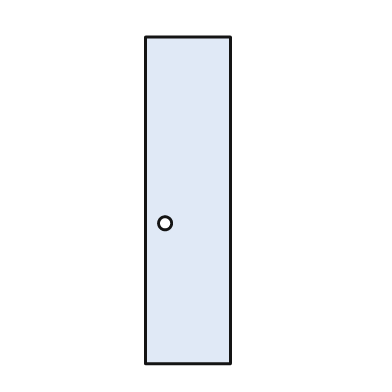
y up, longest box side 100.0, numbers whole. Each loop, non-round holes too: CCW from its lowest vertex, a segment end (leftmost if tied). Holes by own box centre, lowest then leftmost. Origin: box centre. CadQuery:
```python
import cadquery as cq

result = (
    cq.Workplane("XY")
    .moveTo(-13.0, -50.0)
    .lineTo(13.0, -50.0)
    .lineTo(13.0, 50.0)
    .lineTo(-13.0, 50.0)
    .close()
    .moveTo(-7.0, -7.0)
    .circle(2.0)
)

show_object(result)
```